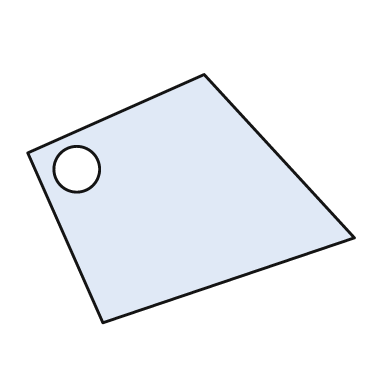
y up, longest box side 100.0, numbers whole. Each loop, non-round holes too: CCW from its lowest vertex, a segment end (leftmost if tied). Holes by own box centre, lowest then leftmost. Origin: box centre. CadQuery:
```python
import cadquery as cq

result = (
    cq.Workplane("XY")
    .moveTo(-27.0, -38.0)
    .lineTo(50.0, -12.0)
    .lineTo(4.0, 38.0)
    .lineTo(-50.0, 14.0)
    .close()
    .moveTo(-35.0, 9.0)
    .circle(7.0)
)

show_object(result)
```